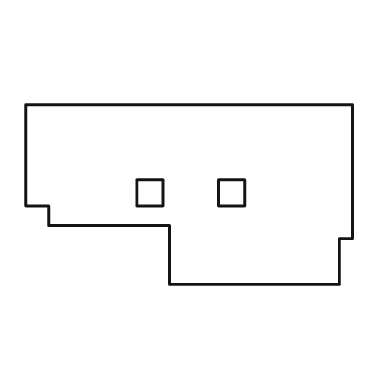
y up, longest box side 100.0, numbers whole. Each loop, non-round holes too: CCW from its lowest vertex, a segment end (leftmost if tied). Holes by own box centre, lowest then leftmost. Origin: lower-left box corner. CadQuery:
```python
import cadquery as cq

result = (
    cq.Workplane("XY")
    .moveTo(44.0, 0.0)
    .lineTo(96.0, 0.0)
    .lineTo(96.0, 14.0)
    .lineTo(100.0, 14.0)
    .lineTo(100.0, 55.0)
    .lineTo(0.0, 55.0)
    .lineTo(0.0, 24.0)
    .lineTo(7.0, 24.0)
    .lineTo(7.0, 18.0)
    .lineTo(44.0, 18.0)
    .close()
    .moveTo(34.0, 24.0)
    .lineTo(42.0, 24.0)
    .lineTo(42.0, 32.0)
    .lineTo(34.0, 32.0)
    .close()
    .moveTo(59.0, 24.0)
    .lineTo(67.0, 24.0)
    .lineTo(67.0, 32.0)
    .lineTo(59.0, 32.0)
    .close()
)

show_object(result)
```